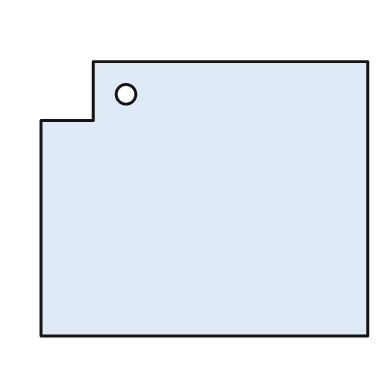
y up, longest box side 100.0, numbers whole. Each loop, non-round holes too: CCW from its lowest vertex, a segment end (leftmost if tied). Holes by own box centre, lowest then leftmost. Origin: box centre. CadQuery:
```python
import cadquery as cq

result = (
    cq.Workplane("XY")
    .moveTo(-50.0, -42.0)
    .lineTo(50.0, -42.0)
    .lineTo(50.0, 42.0)
    .lineTo(-34.0, 42.0)
    .lineTo(-34.0, 24.0)
    .lineTo(-50.0, 24.0)
    .close()
    .moveTo(-24.0, 32.0)
    .circle(3.0)
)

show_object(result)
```